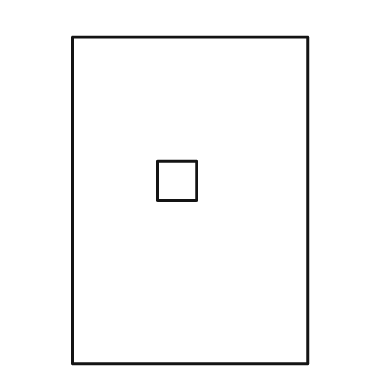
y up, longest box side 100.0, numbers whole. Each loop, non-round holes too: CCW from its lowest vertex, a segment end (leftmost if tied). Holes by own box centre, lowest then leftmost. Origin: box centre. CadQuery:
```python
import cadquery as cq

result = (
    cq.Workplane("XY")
    .moveTo(-36.0, -50.0)
    .lineTo(36.0, -50.0)
    .lineTo(36.0, 50.0)
    .lineTo(-36.0, 50.0)
    .close()
    .moveTo(-10.0, 0.0)
    .lineTo(2.0, 0.0)
    .lineTo(2.0, 12.0)
    .lineTo(-10.0, 12.0)
    .close()
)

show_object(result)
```